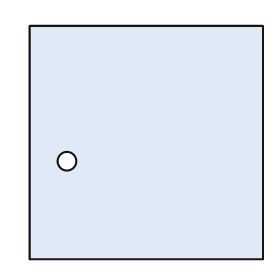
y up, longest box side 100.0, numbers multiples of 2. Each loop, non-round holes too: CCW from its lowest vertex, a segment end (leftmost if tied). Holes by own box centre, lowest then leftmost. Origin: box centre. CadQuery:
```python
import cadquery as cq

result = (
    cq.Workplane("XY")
    .moveTo(-50.0, -50.0)
    .lineTo(50.0, -50.0)
    .lineTo(50.0, 50.0)
    .lineTo(-50.0, 50.0)
    .close()
    .moveTo(-34.0, -8.0)
    .circle(4.0)
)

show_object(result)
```